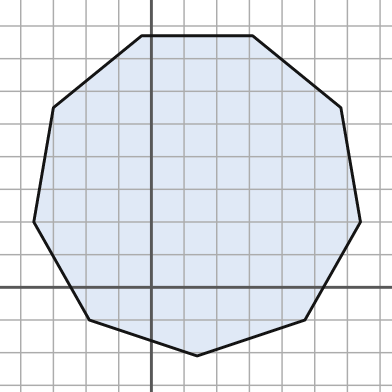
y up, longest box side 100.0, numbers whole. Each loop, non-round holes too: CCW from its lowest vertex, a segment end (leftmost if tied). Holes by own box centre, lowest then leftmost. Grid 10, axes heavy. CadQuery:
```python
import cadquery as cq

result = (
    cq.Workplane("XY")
    .moveTo(14.0, -21.0)
    .lineTo(47.0, -10.0)
    .lineTo(64.0, 20.0)
    .lineTo(58.0, 55.0)
    .lineTo(31.0, 77.0)
    .lineTo(-3.0, 77.0)
    .lineTo(-30.0, 55.0)
    .lineTo(-36.0, 20.0)
    .lineTo(-19.0, -10.0)
    .close()
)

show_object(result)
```